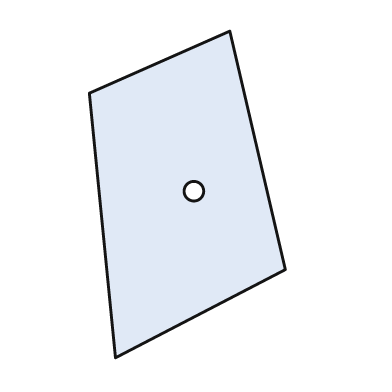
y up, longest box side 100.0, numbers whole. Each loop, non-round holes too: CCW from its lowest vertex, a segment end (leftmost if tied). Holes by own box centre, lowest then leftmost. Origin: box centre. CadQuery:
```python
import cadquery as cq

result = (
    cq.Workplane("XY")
    .moveTo(-22.0, -50.0)
    .lineTo(30.0, -23.0)
    .lineTo(13.0, 50.0)
    .lineTo(-30.0, 31.0)
    .close()
    .moveTo(2.0, 1.0)
    .circle(3.0)
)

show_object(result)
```